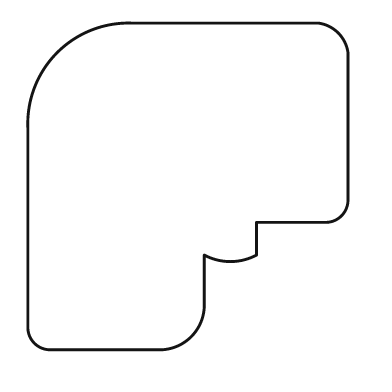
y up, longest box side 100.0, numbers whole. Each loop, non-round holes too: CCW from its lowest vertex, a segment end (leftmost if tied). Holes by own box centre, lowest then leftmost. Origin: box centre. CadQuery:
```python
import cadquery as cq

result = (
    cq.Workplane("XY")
    .moveTo(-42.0, -50.0)
    .lineTo(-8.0, -50.0)
    .threePointArc((1.0, -46.0), (5.0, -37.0))
    .lineTo(5.0, -21.0)
    .threePointArc((13.0, -23.0), (21.0, -21.0))
    .lineTo(21.0, -11.0)
    .lineTo(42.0, -11.0)
    .threePointArc((47.0, -9.0), (49.0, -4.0))
    .lineTo(49.0, 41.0)
    .threePointArc((46.0, 47.0), (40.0, 50.0))
    .lineTo(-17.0, 50.0)
    .threePointArc((-40.0, 41.0), (-49.0, 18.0))
    .lineTo(-49.0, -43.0)
    .threePointArc((-47.0, -48.0), (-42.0, -50.0))
    .close()
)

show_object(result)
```